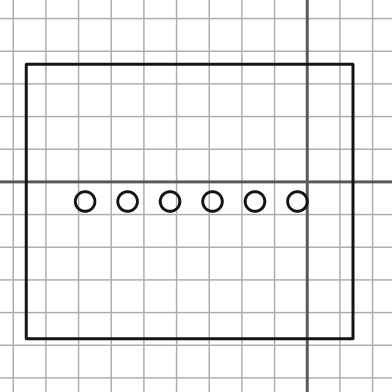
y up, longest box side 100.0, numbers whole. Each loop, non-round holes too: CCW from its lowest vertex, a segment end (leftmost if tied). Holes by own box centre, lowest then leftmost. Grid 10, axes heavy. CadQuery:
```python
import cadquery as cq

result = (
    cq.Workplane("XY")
    .moveTo(-86.0, -48.0)
    .lineTo(14.0, -48.0)
    .lineTo(14.0, 36.0)
    .lineTo(-86.0, 36.0)
    .close()
    .moveTo(-68.0, -6.0)
    .circle(3.0)
    .moveTo(-55.0, -6.0)
    .circle(3.0)
    .moveTo(-42.0, -6.0)
    .circle(3.0)
    .moveTo(-29.0, -6.0)
    .circle(3.0)
    .moveTo(-16.0, -6.0)
    .circle(3.0)
    .moveTo(-3.0, -6.0)
    .circle(3.0)
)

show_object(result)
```